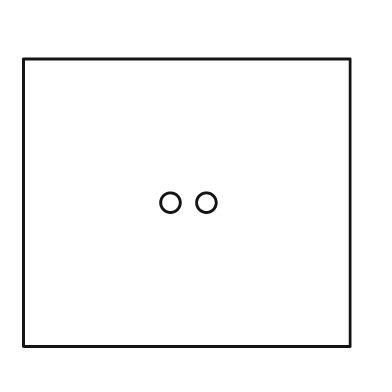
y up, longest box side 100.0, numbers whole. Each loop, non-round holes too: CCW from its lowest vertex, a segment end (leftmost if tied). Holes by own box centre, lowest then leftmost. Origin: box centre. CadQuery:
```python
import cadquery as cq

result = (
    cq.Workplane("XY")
    .moveTo(-50.0, -44.0)
    .lineTo(50.0, -44.0)
    .lineTo(50.0, 44.0)
    .lineTo(-50.0, 44.0)
    .close()
    .moveTo(-5.0, 0.0)
    .circle(3.0)
    .moveTo(6.0, 0.0)
    .circle(3.0)
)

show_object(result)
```